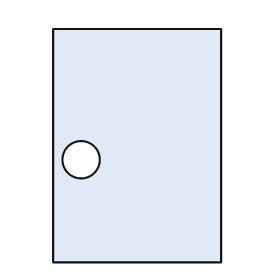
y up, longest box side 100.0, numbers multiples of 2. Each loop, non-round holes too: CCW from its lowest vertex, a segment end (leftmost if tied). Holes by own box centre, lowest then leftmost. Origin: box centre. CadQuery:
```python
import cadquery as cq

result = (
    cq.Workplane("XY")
    .moveTo(-36.0, -50.0)
    .lineTo(36.0, -50.0)
    .lineTo(36.0, 50.0)
    .lineTo(-36.0, 50.0)
    .close()
    .moveTo(-24.0, -6.0)
    .circle(8.0)
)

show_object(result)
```